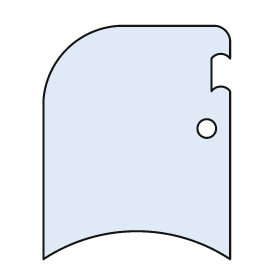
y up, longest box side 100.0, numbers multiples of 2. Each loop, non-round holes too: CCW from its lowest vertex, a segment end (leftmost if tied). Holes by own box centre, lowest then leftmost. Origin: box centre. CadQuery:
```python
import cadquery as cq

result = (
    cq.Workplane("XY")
    .moveTo(-40.0, -50.0)
    .threePointArc((0.0, -38.0), (40.0, -50.0))
    .lineTo(40.0, 22.0)
    .threePointArc((36.0, 24.0), (32.0, 22.0))
    .lineTo(32.0, 36.0)
    .threePointArc((36.0, 38.0), (40.0, 36.0))
    .lineTo(40.0, 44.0)
    .threePointArc((38.0, 48.0), (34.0, 50.0))
    .lineTo(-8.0, 50.0)
    .threePointArc((-30.0, 40.0), (-40.0, 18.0))
    .close()
    .moveTo(30.0, 6.0)
    .circle(4.0)
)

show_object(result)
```